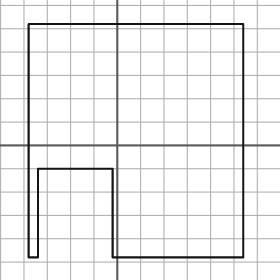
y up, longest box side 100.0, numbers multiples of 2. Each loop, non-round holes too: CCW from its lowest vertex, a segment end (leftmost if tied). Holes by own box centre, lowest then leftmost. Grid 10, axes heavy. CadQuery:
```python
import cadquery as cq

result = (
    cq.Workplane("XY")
    .moveTo(-38.0, -48.0)
    .lineTo(-34.0, -48.0)
    .lineTo(-34.0, -10.0)
    .lineTo(-2.0, -10.0)
    .lineTo(-2.0, -48.0)
    .lineTo(54.0, -48.0)
    .lineTo(54.0, 52.0)
    .lineTo(-38.0, 52.0)
    .close()
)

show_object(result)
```